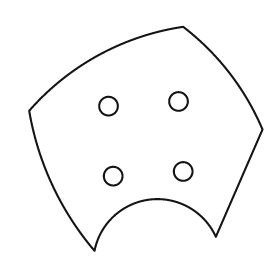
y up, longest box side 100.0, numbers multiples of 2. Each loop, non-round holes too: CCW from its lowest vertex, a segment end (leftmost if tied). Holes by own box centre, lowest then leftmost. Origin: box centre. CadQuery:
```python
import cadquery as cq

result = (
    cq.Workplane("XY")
    .moveTo(-22.0, -48.0)
    .threePointArc((2.0, -26.0), (30.0, -42.0))
    .lineTo(50.0, 4.0)
    .threePointArc((36.0, 28.0), (16.0, 48.0))
    .threePointArc((-20.0, 36.0), (-50.0, 12.0))
    .threePointArc((-40.0, -20.0), (-22.0, -48.0))
    .close()
    .moveTo(-14.0, -16.0)
    .circle(4.0)
    .moveTo(16.0, -14.0)
    .circle(4.0)
    .moveTo(-16.0, 14.0)
    .circle(4.0)
    .moveTo(14.0, 16.0)
    .circle(4.0)
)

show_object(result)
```